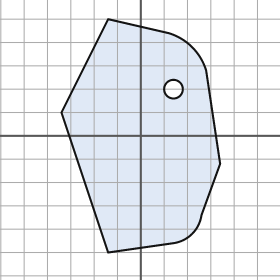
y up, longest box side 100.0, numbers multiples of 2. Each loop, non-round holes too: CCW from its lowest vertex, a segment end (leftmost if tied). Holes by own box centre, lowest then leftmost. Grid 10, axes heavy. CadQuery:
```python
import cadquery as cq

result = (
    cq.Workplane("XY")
    .moveTo(-14.0, -50.0)
    .lineTo(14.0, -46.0)
    .threePointArc((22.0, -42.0), (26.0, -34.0))
    .lineTo(34.0, -12.0)
    .lineTo(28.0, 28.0)
    .threePointArc((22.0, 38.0), (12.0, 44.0))
    .lineTo(-14.0, 50.0)
    .lineTo(-34.0, 10.0)
    .close()
    .moveTo(14.0, 20.0)
    .circle(4.0)
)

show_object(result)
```